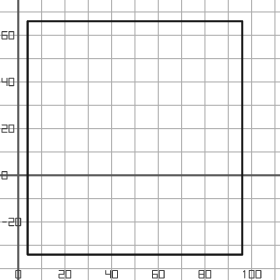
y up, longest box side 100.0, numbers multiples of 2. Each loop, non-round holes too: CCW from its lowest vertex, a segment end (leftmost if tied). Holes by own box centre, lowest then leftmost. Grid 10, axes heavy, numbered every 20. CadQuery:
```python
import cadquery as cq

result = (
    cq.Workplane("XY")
    .moveTo(4.0, -34.0)
    .lineTo(96.0, -34.0)
    .lineTo(96.0, 66.0)
    .lineTo(4.0, 66.0)
    .close()
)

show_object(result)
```